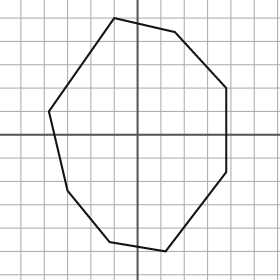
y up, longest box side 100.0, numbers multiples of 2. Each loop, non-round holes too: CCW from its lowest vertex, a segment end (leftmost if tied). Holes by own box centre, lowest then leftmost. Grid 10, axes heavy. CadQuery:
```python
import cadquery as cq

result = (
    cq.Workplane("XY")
    .moveTo(12.0, -50.0)
    .lineTo(38.0, -16.0)
    .lineTo(38.0, 20.0)
    .lineTo(16.0, 44.0)
    .lineTo(-10.0, 50.0)
    .lineTo(-38.0, 10.0)
    .lineTo(-30.0, -24.0)
    .lineTo(-12.0, -46.0)
    .close()
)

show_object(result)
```